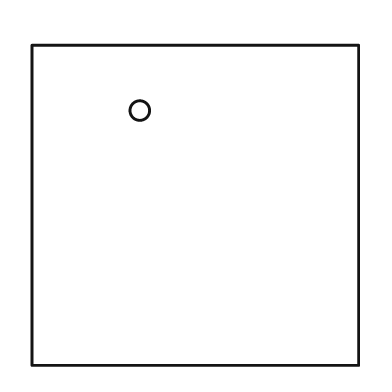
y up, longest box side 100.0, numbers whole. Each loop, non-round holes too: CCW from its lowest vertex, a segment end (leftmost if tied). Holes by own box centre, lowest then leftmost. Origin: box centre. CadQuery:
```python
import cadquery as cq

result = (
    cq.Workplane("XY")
    .moveTo(-50.0, -49.0)
    .lineTo(50.0, -49.0)
    .lineTo(50.0, 49.0)
    .lineTo(-50.0, 49.0)
    .close()
    .moveTo(-17.0, 29.0)
    .circle(3.0)
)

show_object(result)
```